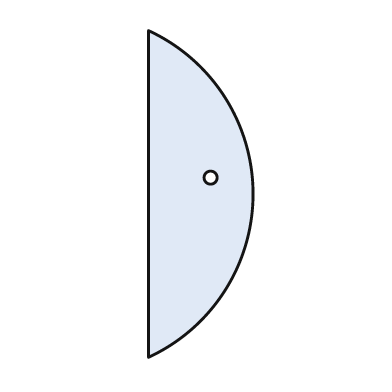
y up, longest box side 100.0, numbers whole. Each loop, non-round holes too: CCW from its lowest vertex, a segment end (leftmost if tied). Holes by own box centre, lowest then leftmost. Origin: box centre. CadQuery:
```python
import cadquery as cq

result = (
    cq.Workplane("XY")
    .moveTo(-16.0, -50.0)
    .threePointArc((16.0, 0.0), (-16.0, 50.0))
    .close()
    .moveTo(3.0, 5.0)
    .circle(2.0)
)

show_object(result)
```